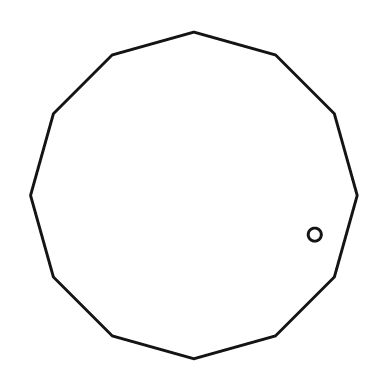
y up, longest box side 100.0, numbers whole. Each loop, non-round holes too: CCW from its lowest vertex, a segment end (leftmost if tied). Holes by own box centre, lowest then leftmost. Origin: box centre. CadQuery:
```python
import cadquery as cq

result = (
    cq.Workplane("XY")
    .moveTo(0.0, -50.0)
    .lineTo(25.0, -43.0)
    .lineTo(43.0, -25.0)
    .lineTo(50.0, 0.0)
    .lineTo(43.0, 25.0)
    .lineTo(25.0, 43.0)
    .lineTo(0.0, 50.0)
    .lineTo(-25.0, 43.0)
    .lineTo(-43.0, 25.0)
    .lineTo(-50.0, 0.0)
    .lineTo(-43.0, -25.0)
    .lineTo(-25.0, -43.0)
    .close()
    .moveTo(37.0, -12.0)
    .circle(2.0)
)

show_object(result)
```